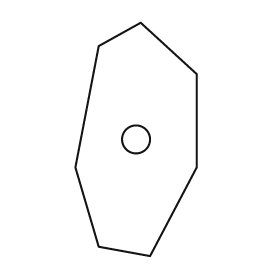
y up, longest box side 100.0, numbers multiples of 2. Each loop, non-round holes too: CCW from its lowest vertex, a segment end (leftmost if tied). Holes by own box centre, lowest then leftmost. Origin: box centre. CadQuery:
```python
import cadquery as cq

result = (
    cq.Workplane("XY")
    .moveTo(6.0, -50.0)
    .lineTo(26.0, -12.0)
    .lineTo(26.0, 28.0)
    .lineTo(2.0, 50.0)
    .lineTo(-16.0, 40.0)
    .lineTo(-26.0, -12.0)
    .lineTo(-16.0, -46.0)
    .close()
    .moveTo(0.0, 0.0)
    .circle(6.0)
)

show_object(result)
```